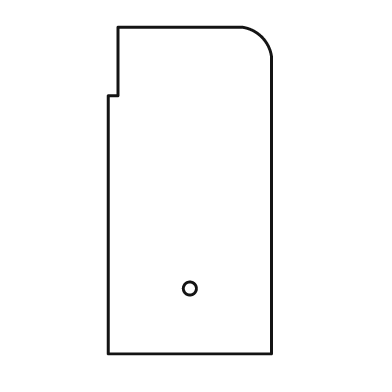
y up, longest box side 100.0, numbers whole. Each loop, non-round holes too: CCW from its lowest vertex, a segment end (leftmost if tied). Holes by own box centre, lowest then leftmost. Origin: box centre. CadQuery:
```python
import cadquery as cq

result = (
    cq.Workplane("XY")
    .moveTo(-25.0, -50.0)
    .lineTo(25.0, -50.0)
    .lineTo(25.0, 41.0)
    .threePointArc((22.0, 47.0), (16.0, 50.0))
    .lineTo(-22.0, 50.0)
    .lineTo(-22.0, 29.0)
    .lineTo(-25.0, 29.0)
    .close()
    .moveTo(0.0, -30.0)
    .circle(2.0)
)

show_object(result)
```